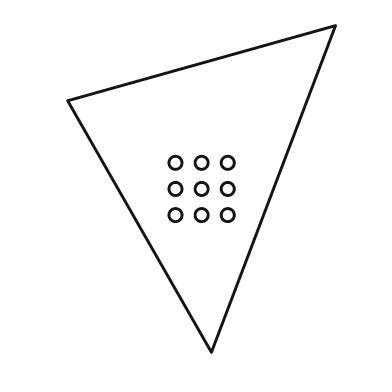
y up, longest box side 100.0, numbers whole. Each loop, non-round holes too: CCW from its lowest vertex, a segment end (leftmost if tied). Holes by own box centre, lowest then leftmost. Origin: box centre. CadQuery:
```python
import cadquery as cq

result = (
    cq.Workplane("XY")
    .moveTo(3.0, -50.0)
    .lineTo(41.0, 50.0)
    .lineTo(-41.0, 27.0)
    .close()
    .moveTo(-8.0, -8.0)
    .circle(2.0)
    .moveTo(0.0, -8.0)
    .circle(2.0)
    .moveTo(8.0, -8.0)
    .circle(2.0)
    .moveTo(-8.0, 0.0)
    .circle(2.0)
    .moveTo(0.0, 0.0)
    .circle(2.0)
    .moveTo(8.0, 0.0)
    .circle(2.0)
    .moveTo(-8.0, 8.0)
    .circle(2.0)
    .moveTo(0.0, 8.0)
    .circle(2.0)
    .moveTo(8.0, 8.0)
    .circle(2.0)
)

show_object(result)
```